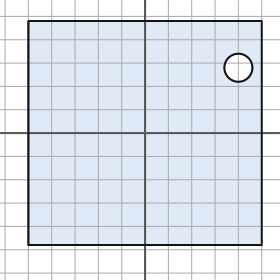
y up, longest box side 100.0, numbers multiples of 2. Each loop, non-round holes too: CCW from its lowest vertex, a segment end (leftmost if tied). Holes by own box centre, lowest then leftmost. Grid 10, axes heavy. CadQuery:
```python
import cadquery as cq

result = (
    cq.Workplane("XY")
    .moveTo(-50.0, -48.0)
    .lineTo(50.0, -48.0)
    .lineTo(50.0, 48.0)
    .lineTo(-50.0, 48.0)
    .close()
    .moveTo(40.0, 28.0)
    .circle(6.0)
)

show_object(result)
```